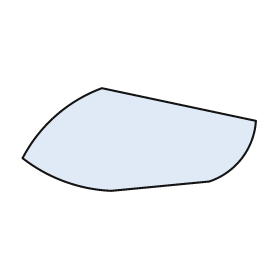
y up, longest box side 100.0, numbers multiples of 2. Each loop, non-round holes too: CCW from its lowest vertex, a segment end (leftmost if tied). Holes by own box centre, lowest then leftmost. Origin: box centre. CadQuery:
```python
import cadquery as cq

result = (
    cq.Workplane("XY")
    .moveTo(-12.0, -22.0)
    .lineTo(30.0, -18.0)
    .threePointArc((44.0, -8.0), (50.0, 8.0))
    .lineTo(-16.0, 22.0)
    .threePointArc((-36.0, 10.0), (-50.0, -8.0))
    .threePointArc((-32.0, -18.0), (-12.0, -22.0))
    .close()
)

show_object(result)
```